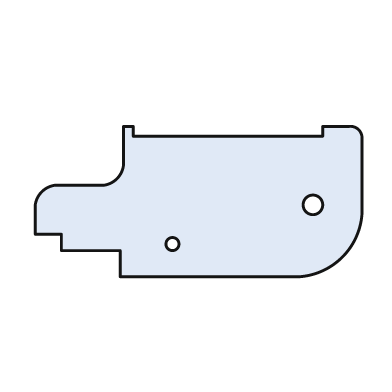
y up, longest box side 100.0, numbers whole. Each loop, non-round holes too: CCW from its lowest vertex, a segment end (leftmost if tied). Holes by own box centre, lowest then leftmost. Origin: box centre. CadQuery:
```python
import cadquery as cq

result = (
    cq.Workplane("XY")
    .moveTo(-24.0, -23.0)
    .lineTo(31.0, -23.0)
    .threePointArc((44.0, -17.0), (50.0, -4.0))
    .lineTo(50.0, 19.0)
    .threePointArc((49.0, 22.0), (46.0, 23.0))
    .lineTo(38.0, 23.0)
    .lineTo(38.0, 20.0)
    .lineTo(-20.0, 20.0)
    .lineTo(-20.0, 23.0)
    .lineTo(-23.0, 23.0)
    .lineTo(-23.0, 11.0)
    .threePointArc((-25.0, 7.0), (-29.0, 5.0))
    .lineTo(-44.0, 5.0)
    .threePointArc((-48.0, 3.0), (-50.0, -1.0))
    .lineTo(-50.0, -10.0)
    .lineTo(-42.0, -10.0)
    .lineTo(-42.0, -15.0)
    .lineTo(-24.0, -15.0)
    .close()
    .moveTo(-8.0, -13.0)
    .circle(2.0)
    .moveTo(35.0, -1.0)
    .circle(3.0)
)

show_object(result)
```